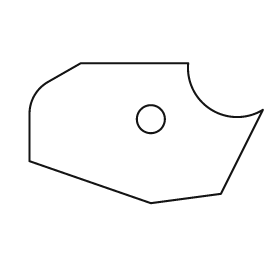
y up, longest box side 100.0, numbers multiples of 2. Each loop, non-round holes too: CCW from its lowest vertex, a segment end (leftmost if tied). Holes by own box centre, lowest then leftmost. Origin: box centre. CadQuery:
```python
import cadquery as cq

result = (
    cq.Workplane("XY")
    .moveTo(2.0, -30.0)
    .lineTo(32.0, -26.0)
    .lineTo(50.0, 10.0)
    .threePointArc((28.0, 10.0), (18.0, 30.0))
    .lineTo(-28.0, 30.0)
    .lineTo(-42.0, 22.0)
    .threePointArc((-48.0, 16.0), (-50.0, 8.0))
    .lineTo(-50.0, -12.0)
    .close()
    .moveTo(2.0, 6.0)
    .circle(6.0)
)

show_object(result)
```